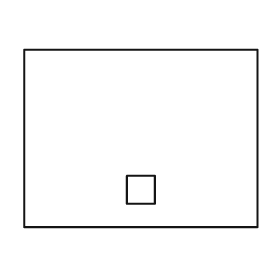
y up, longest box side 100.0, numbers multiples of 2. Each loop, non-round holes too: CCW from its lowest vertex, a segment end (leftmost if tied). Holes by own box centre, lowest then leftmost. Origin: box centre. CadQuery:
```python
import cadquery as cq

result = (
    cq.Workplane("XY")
    .moveTo(-50.0, -38.0)
    .lineTo(50.0, -38.0)
    .lineTo(50.0, 38.0)
    .lineTo(-50.0, 38.0)
    .close()
    .moveTo(-6.0, -28.0)
    .lineTo(6.0, -28.0)
    .lineTo(6.0, -16.0)
    .lineTo(-6.0, -16.0)
    .close()
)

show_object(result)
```